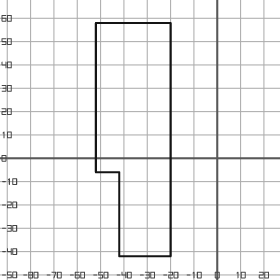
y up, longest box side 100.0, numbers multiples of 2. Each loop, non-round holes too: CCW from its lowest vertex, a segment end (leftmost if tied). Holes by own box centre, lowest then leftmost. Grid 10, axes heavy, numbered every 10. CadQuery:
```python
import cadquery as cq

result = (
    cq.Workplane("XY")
    .moveTo(-42.0, -42.0)
    .lineTo(-20.0, -42.0)
    .lineTo(-20.0, 58.0)
    .lineTo(-52.0, 58.0)
    .lineTo(-52.0, -6.0)
    .lineTo(-42.0, -6.0)
    .close()
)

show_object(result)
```